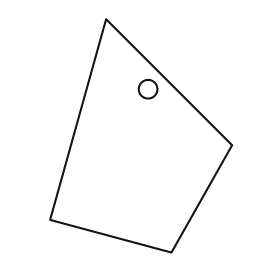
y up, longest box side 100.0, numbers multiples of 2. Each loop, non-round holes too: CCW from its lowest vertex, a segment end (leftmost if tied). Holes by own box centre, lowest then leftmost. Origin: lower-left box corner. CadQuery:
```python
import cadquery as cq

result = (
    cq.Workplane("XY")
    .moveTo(52.0, 0.0)
    .lineTo(78.0, 46.0)
    .lineTo(24.0, 100.0)
    .lineTo(0.0, 14.0)
    .close()
    .moveTo(42.0, 70.0)
    .circle(4.0)
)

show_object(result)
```